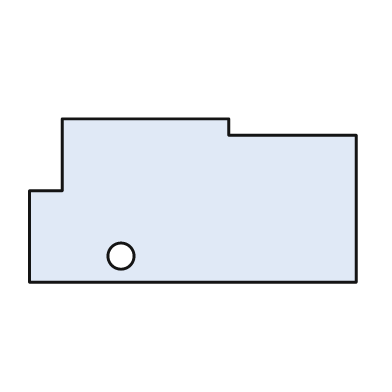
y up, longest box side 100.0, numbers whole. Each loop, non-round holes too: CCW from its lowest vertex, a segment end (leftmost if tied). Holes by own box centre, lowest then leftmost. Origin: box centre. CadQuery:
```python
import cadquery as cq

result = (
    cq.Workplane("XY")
    .moveTo(-50.0, -25.0)
    .lineTo(50.0, -25.0)
    .lineTo(50.0, 20.0)
    .lineTo(11.0, 20.0)
    .lineTo(11.0, 25.0)
    .lineTo(-40.0, 25.0)
    .lineTo(-40.0, 3.0)
    .lineTo(-50.0, 3.0)
    .close()
    .moveTo(-22.0, -17.0)
    .circle(4.0)
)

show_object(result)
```